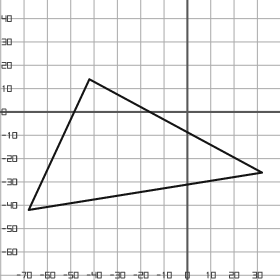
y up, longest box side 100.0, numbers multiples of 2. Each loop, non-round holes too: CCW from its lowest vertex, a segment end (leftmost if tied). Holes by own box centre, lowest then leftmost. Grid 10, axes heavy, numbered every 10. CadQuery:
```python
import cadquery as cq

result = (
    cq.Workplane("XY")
    .moveTo(-68.0, -42.0)
    .lineTo(32.0, -26.0)
    .lineTo(-42.0, 14.0)
    .close()
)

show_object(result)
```